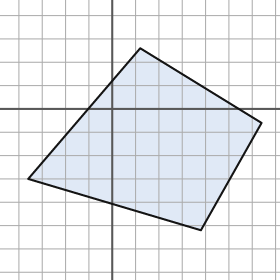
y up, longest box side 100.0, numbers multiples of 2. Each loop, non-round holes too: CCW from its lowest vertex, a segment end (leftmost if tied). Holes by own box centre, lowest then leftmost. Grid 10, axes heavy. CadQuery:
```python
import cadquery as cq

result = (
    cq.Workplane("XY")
    .moveTo(38.0, -52.0)
    .lineTo(64.0, -6.0)
    .lineTo(12.0, 26.0)
    .lineTo(-36.0, -30.0)
    .close()
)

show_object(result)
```